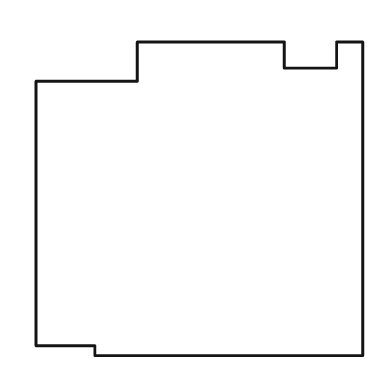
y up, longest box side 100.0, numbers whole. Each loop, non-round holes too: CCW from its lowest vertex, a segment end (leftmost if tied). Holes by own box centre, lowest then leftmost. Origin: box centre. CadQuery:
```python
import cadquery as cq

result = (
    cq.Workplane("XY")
    .moveTo(-32.0, -48.0)
    .lineTo(50.0, -48.0)
    .lineTo(50.0, 48.0)
    .lineTo(42.0, 48.0)
    .lineTo(42.0, 40.0)
    .lineTo(26.0, 40.0)
    .lineTo(26.0, 48.0)
    .lineTo(-19.0, 48.0)
    .lineTo(-19.0, 36.0)
    .lineTo(-50.0, 36.0)
    .lineTo(-50.0, -45.0)
    .lineTo(-32.0, -45.0)
    .close()
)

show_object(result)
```